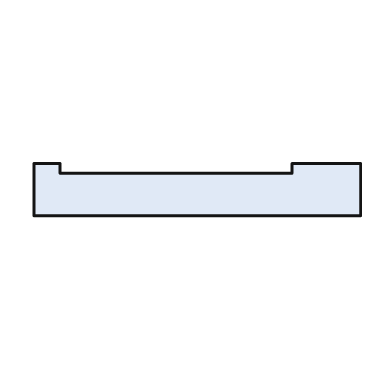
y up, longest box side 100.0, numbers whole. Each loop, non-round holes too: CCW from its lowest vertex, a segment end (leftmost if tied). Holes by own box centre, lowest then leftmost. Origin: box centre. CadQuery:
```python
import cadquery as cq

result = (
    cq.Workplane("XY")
    .moveTo(-50.0, -8.0)
    .lineTo(50.0, -8.0)
    .lineTo(50.0, 8.0)
    .lineTo(29.0, 8.0)
    .lineTo(29.0, 5.0)
    .lineTo(-42.0, 5.0)
    .lineTo(-42.0, 8.0)
    .lineTo(-50.0, 8.0)
    .close()
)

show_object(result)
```